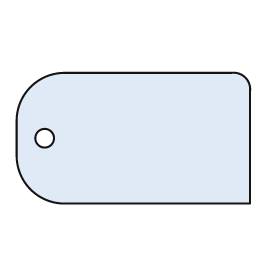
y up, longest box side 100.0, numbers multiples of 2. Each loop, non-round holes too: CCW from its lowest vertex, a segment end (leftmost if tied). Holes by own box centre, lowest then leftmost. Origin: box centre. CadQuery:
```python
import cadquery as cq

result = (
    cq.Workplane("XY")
    .moveTo(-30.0, -28.0)
    .lineTo(50.0, -28.0)
    .lineTo(50.0, 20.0)
    .threePointArc((48.0, 26.0), (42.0, 28.0))
    .lineTo(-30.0, 28.0)
    .threePointArc((-44.0, 22.0), (-50.0, 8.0))
    .lineTo(-50.0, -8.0)
    .threePointArc((-44.0, -22.0), (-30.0, -28.0))
    .close()
    .moveTo(-38.0, 0.0)
    .circle(4.0)
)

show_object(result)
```